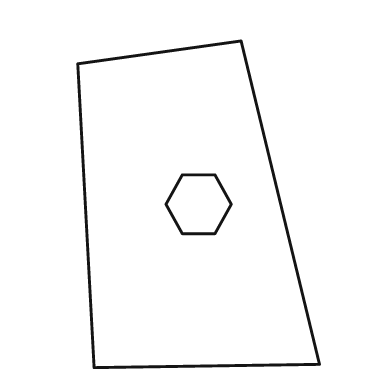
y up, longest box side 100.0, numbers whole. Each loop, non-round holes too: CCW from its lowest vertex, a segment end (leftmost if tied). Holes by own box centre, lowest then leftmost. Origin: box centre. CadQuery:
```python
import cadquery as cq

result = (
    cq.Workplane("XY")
    .moveTo(-32.0, -50.0)
    .lineTo(37.0, -49.0)
    .lineTo(13.0, 50.0)
    .lineTo(-37.0, 43.0)
    .close()
    .moveTo(-5.0, -9.0)
    .lineTo(5.0, -9.0)
    .lineTo(10.0, 0.0)
    .lineTo(5.0, 9.0)
    .lineTo(-5.0, 9.0)
    .lineTo(-10.0, 0.0)
    .close()
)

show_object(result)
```